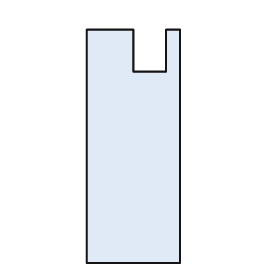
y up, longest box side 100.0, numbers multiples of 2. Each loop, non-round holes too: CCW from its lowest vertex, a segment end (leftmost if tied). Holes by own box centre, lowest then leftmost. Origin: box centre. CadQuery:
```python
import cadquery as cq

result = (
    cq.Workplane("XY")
    .moveTo(-20.0, -50.0)
    .lineTo(20.0, -50.0)
    .lineTo(20.0, 50.0)
    .lineTo(14.0, 50.0)
    .lineTo(14.0, 32.0)
    .lineTo(0.0, 32.0)
    .lineTo(0.0, 50.0)
    .lineTo(-20.0, 50.0)
    .close()
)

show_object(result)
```